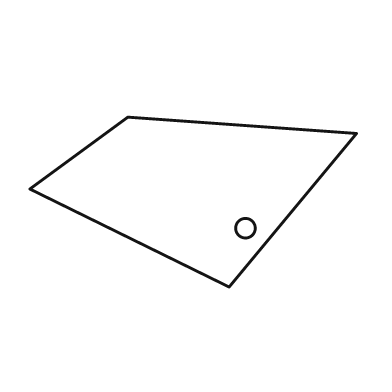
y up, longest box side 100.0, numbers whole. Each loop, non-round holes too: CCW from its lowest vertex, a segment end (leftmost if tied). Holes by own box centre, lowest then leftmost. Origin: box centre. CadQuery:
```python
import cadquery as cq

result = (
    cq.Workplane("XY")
    .moveTo(11.0, -26.0)
    .lineTo(50.0, 21.0)
    .lineTo(-20.0, 26.0)
    .lineTo(-50.0, 4.0)
    .close()
    .moveTo(16.0, -8.0)
    .circle(3.0)
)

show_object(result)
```